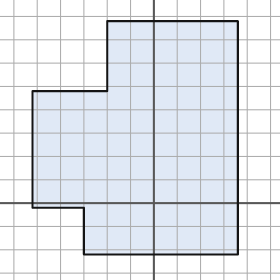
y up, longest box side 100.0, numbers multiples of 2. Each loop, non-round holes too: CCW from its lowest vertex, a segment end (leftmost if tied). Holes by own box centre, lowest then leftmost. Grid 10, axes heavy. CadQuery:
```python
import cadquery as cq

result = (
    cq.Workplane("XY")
    .moveTo(-30.0, -22.0)
    .lineTo(36.0, -22.0)
    .lineTo(36.0, 78.0)
    .lineTo(-20.0, 78.0)
    .lineTo(-20.0, 48.0)
    .lineTo(-52.0, 48.0)
    .lineTo(-52.0, -2.0)
    .lineTo(-30.0, -2.0)
    .close()
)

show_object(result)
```